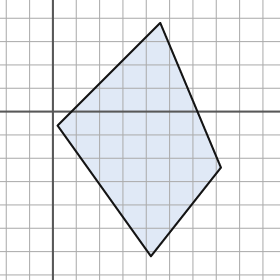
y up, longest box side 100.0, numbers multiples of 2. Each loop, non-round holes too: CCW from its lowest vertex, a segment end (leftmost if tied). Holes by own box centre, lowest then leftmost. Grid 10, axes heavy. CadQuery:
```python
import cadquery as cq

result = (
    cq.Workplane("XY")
    .moveTo(42.0, -62.0)
    .lineTo(72.0, -24.0)
    .lineTo(46.0, 38.0)
    .lineTo(2.0, -6.0)
    .close()
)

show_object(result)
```